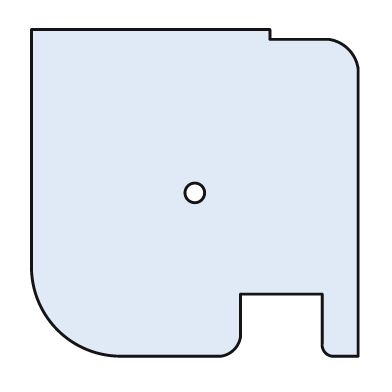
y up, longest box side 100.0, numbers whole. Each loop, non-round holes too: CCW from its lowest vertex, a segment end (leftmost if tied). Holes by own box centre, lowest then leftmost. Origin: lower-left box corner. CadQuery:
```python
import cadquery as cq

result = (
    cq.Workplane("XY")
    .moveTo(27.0, 0.0)
    .lineTo(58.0, 0.0)
    .threePointArc((62.0, 2.0), (64.0, 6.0))
    .lineTo(64.0, 19.0)
    .lineTo(89.0, 19.0)
    .lineTo(89.0, 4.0)
    .threePointArc((90.0, 1.0), (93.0, 0.0))
    .lineTo(100.0, 0.0)
    .lineTo(100.0, 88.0)
    .threePointArc((97.0, 94.0), (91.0, 97.0))
    .lineTo(73.0, 97.0)
    .lineTo(73.0, 100.0)
    .lineTo(0.0, 100.0)
    .lineTo(0.0, 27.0)
    .threePointArc((8.0, 8.0), (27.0, 0.0))
    .close()
    .moveTo(50.0, 50.0)
    .circle(3.0)
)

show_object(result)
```